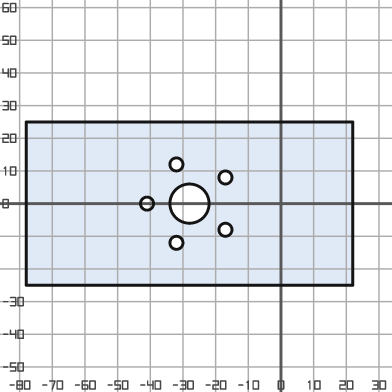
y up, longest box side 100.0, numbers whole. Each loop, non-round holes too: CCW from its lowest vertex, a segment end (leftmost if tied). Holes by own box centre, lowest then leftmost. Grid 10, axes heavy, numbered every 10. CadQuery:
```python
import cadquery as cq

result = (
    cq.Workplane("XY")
    .moveTo(-78.0, -25.0)
    .lineTo(22.0, -25.0)
    .lineTo(22.0, 25.0)
    .lineTo(-78.0, 25.0)
    .close()
    .moveTo(-32.0, -12.0)
    .circle(2.0)
    .moveTo(-17.0, -8.0)
    .circle(2.0)
    .moveTo(-41.0, 0.0)
    .circle(2.0)
    .moveTo(-28.0, 0.0)
    .circle(6.0)
    .moveTo(-17.0, 8.0)
    .circle(2.0)
    .moveTo(-32.0, 12.0)
    .circle(2.0)
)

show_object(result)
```